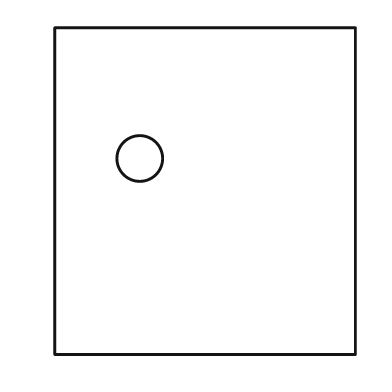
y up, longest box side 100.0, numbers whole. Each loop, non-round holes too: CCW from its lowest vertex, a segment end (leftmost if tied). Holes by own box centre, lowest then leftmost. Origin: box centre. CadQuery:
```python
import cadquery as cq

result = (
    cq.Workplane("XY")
    .moveTo(-46.0, -50.0)
    .lineTo(46.0, -50.0)
    .lineTo(46.0, 50.0)
    .lineTo(-46.0, 50.0)
    .close()
    .moveTo(-20.0, 10.0)
    .circle(7.0)
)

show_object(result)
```